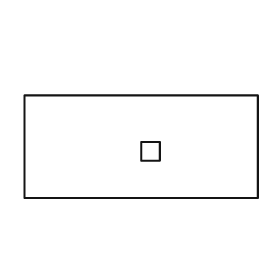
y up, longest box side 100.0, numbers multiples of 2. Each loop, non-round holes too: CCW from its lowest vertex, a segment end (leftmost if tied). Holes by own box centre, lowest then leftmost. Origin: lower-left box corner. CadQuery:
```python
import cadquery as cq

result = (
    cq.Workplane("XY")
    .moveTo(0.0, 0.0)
    .lineTo(100.0, 0.0)
    .lineTo(100.0, 44.0)
    .lineTo(0.0, 44.0)
    .close()
    .moveTo(50.0, 16.0)
    .lineTo(58.0, 16.0)
    .lineTo(58.0, 24.0)
    .lineTo(50.0, 24.0)
    .close()
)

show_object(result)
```